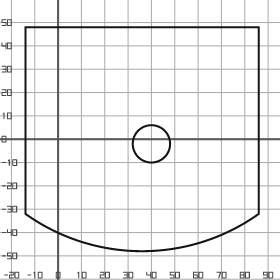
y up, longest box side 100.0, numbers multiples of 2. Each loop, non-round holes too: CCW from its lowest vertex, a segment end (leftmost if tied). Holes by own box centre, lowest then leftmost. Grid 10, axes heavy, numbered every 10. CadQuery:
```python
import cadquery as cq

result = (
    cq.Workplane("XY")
    .moveTo(-14.0, -32.0)
    .threePointArc((36.0, -48.0), (86.0, -32.0))
    .lineTo(86.0, 48.0)
    .lineTo(-14.0, 48.0)
    .close()
    .moveTo(40.0, -2.0)
    .circle(8.0)
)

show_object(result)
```